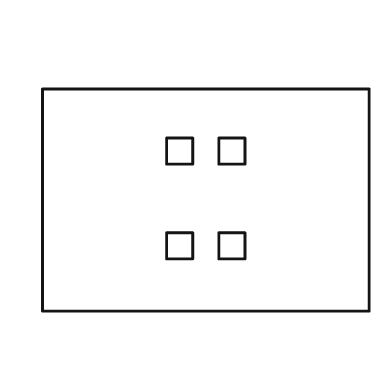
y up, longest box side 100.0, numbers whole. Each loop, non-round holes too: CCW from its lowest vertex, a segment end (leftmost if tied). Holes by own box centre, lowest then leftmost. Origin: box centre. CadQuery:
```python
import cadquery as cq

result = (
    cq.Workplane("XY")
    .moveTo(-50.0, -34.0)
    .lineTo(50.0, -34.0)
    .lineTo(50.0, 34.0)
    .lineTo(-50.0, 34.0)
    .close()
    .moveTo(-12.0, -18.0)
    .lineTo(-4.0, -18.0)
    .lineTo(-4.0, -10.0)
    .lineTo(-12.0, -10.0)
    .close()
    .moveTo(4.0, -18.0)
    .lineTo(12.0, -18.0)
    .lineTo(12.0, -10.0)
    .lineTo(4.0, -10.0)
    .close()
    .moveTo(-12.0, 11.0)
    .lineTo(-4.0, 11.0)
    .lineTo(-4.0, 19.0)
    .lineTo(-12.0, 19.0)
    .close()
    .moveTo(4.0, 11.0)
    .lineTo(12.0, 11.0)
    .lineTo(12.0, 19.0)
    .lineTo(4.0, 19.0)
    .close()
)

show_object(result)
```